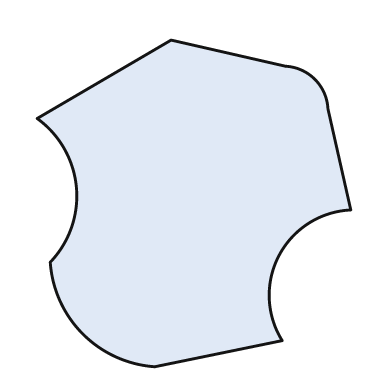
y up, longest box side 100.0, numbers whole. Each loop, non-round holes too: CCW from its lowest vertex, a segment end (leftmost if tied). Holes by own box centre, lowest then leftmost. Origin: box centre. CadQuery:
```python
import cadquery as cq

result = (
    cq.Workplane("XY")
    .moveTo(-12.0, -50.0)
    .lineTo(27.0, -42.0)
    .threePointArc((26.0, -16.0), (48.0, -2.0))
    .lineTo(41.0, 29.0)
    .threePointArc((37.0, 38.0), (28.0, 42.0))
    .lineTo(-7.0, 50.0)
    .lineTo(-48.0, 26.0)
    .threePointArc((-36.0, 5.0), (-44.0, -18.0))
    .threePointArc((-34.0, -40.0), (-12.0, -50.0))
    .close()
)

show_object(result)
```